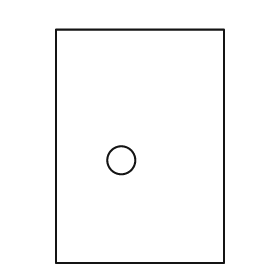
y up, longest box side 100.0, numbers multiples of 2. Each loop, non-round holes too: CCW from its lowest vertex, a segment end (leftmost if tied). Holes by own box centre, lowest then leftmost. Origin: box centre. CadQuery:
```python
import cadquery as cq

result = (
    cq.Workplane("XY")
    .moveTo(-36.0, -50.0)
    .lineTo(36.0, -50.0)
    .lineTo(36.0, 50.0)
    .lineTo(-36.0, 50.0)
    .close()
    .moveTo(-8.0, -6.0)
    .circle(6.0)
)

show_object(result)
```